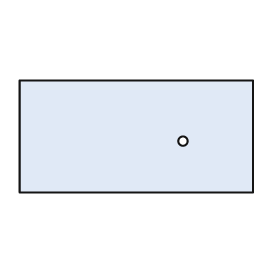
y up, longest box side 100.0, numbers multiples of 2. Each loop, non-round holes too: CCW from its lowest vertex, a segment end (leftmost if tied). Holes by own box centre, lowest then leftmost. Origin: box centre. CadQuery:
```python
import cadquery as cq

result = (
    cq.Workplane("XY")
    .moveTo(-50.0, -24.0)
    .lineTo(50.0, -24.0)
    .lineTo(50.0, 24.0)
    .lineTo(-50.0, 24.0)
    .close()
    .moveTo(20.0, -2.0)
    .circle(2.0)
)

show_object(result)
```